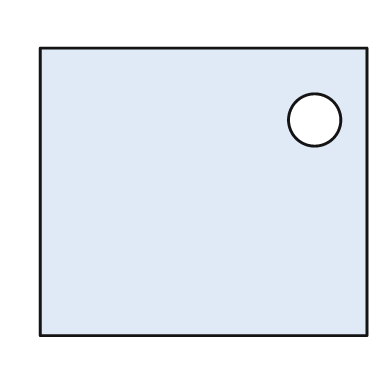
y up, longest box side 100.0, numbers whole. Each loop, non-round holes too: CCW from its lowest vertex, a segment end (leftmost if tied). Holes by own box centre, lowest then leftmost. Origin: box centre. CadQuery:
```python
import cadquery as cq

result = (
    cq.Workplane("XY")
    .moveTo(-50.0, -44.0)
    .lineTo(50.0, -44.0)
    .lineTo(50.0, 44.0)
    .lineTo(-50.0, 44.0)
    .close()
    .moveTo(34.0, 22.0)
    .circle(8.0)
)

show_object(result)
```